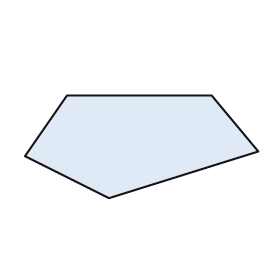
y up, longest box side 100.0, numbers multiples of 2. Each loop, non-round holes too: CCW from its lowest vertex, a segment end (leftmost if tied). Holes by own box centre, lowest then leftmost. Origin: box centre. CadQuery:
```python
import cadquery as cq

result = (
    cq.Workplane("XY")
    .moveTo(-14.0, -22.0)
    .lineTo(50.0, -2.0)
    .lineTo(30.0, 22.0)
    .lineTo(-32.0, 22.0)
    .lineTo(-50.0, -4.0)
    .close()
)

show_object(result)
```